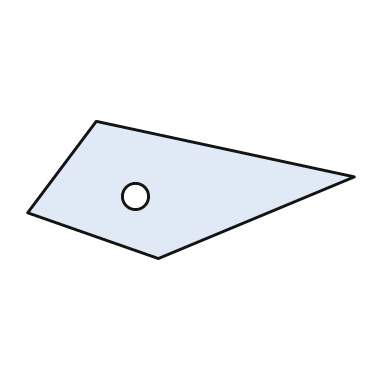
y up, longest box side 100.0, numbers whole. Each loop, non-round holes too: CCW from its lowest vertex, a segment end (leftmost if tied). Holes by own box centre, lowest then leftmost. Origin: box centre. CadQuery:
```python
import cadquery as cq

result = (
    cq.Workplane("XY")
    .moveTo(-10.0, -21.0)
    .lineTo(50.0, 4.0)
    .lineTo(-29.0, 21.0)
    .lineTo(-50.0, -7.0)
    .close()
    .moveTo(-17.0, -2.0)
    .circle(4.0)
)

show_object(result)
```